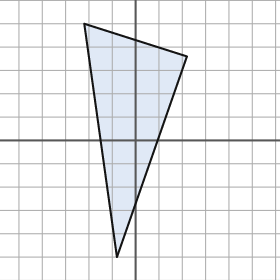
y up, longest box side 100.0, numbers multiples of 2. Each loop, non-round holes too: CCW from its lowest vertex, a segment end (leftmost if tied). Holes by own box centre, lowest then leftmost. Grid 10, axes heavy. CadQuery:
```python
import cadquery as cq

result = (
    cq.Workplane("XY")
    .moveTo(-8.0, -50.0)
    .lineTo(22.0, 36.0)
    .lineTo(-22.0, 50.0)
    .close()
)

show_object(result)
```